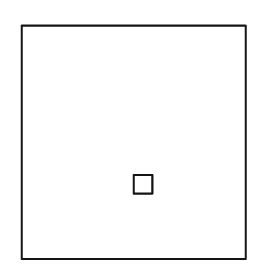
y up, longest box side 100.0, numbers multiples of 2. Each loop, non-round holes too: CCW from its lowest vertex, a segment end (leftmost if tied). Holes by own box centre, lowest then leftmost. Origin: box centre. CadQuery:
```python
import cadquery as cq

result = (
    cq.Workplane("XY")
    .moveTo(-48.0, -50.0)
    .lineTo(48.0, -50.0)
    .lineTo(48.0, 50.0)
    .lineTo(-48.0, 50.0)
    .close()
    .moveTo(0.0, -22.0)
    .lineTo(8.0, -22.0)
    .lineTo(8.0, -14.0)
    .lineTo(0.0, -14.0)
    .close()
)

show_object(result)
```